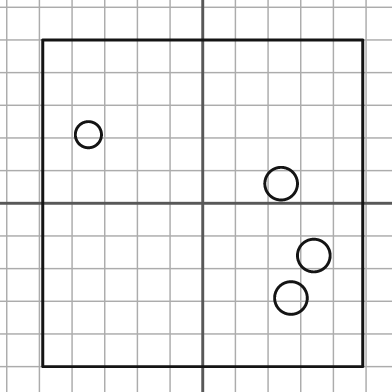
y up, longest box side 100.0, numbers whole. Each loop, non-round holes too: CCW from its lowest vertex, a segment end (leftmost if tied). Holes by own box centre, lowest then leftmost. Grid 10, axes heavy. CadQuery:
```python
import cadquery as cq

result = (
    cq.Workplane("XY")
    .moveTo(-49.0, -50.0)
    .lineTo(49.0, -50.0)
    .lineTo(49.0, 50.0)
    .lineTo(-49.0, 50.0)
    .close()
    .moveTo(27.0, -29.0)
    .circle(5.0)
    .moveTo(34.0, -16.0)
    .circle(5.0)
    .moveTo(24.0, 6.0)
    .circle(5.0)
    .moveTo(-35.0, 21.0)
    .circle(4.0)
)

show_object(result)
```